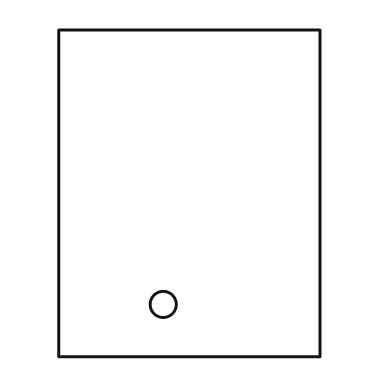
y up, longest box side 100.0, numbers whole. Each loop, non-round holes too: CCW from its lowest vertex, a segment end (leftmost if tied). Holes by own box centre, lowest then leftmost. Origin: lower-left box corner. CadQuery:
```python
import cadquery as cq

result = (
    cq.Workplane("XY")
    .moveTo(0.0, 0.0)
    .lineTo(80.0, 0.0)
    .lineTo(80.0, 100.0)
    .lineTo(0.0, 100.0)
    .close()
    .moveTo(32.0, 16.0)
    .circle(4.0)
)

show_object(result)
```